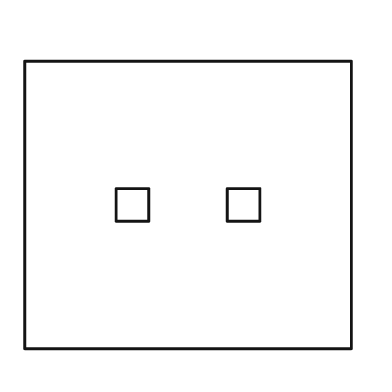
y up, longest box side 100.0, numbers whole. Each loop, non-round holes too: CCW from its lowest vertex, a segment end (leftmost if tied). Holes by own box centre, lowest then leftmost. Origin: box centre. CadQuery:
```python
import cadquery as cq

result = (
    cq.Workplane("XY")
    .moveTo(-50.0, -44.0)
    .lineTo(50.0, -44.0)
    .lineTo(50.0, 44.0)
    .lineTo(-50.0, 44.0)
    .close()
    .moveTo(-22.0, -5.0)
    .lineTo(-12.0, -5.0)
    .lineTo(-12.0, 5.0)
    .lineTo(-22.0, 5.0)
    .close()
    .moveTo(12.0, -5.0)
    .lineTo(22.0, -5.0)
    .lineTo(22.0, 5.0)
    .lineTo(12.0, 5.0)
    .close()
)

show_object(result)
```